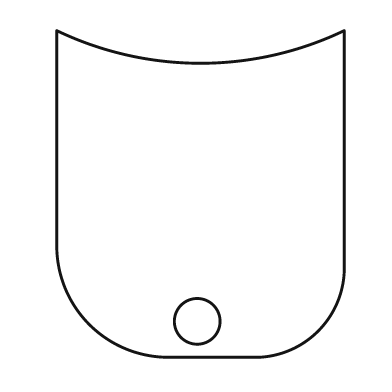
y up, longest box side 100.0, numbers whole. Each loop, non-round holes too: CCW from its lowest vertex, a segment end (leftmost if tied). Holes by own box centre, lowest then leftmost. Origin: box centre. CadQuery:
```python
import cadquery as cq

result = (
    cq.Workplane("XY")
    .moveTo(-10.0, -50.0)
    .lineTo(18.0, -50.0)
    .threePointArc((36.0, -42.0), (44.0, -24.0))
    .lineTo(44.0, 50.0)
    .threePointArc((0.0, 40.0), (-44.0, 50.0))
    .lineTo(-44.0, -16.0)
    .threePointArc((-34.0, -40.0), (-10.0, -50.0))
    .close()
    .moveTo(-1.0, -39.0)
    .circle(7.0)
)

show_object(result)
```